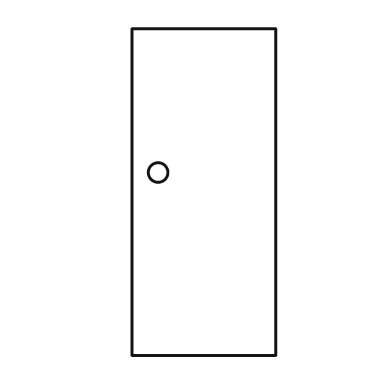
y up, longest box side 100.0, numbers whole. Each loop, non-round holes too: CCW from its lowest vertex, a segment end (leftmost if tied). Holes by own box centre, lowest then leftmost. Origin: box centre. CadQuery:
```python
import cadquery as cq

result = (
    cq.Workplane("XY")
    .moveTo(-22.0, -50.0)
    .lineTo(22.0, -50.0)
    .lineTo(22.0, 50.0)
    .lineTo(-22.0, 50.0)
    .close()
    .moveTo(-14.0, 6.0)
    .circle(3.0)
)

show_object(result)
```